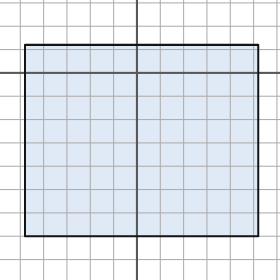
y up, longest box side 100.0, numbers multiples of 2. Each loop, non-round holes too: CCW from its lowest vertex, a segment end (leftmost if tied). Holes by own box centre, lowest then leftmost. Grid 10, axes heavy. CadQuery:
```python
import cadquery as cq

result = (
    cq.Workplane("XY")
    .moveTo(-48.0, -70.0)
    .lineTo(52.0, -70.0)
    .lineTo(52.0, 12.0)
    .lineTo(-48.0, 12.0)
    .close()
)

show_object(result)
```